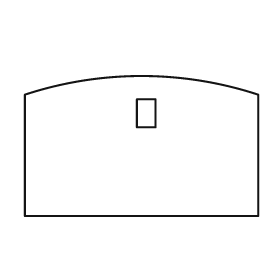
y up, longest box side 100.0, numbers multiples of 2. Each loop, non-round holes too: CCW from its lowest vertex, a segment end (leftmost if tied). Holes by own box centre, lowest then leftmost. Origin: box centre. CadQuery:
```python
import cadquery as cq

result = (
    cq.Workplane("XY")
    .moveTo(-50.0, -30.0)
    .lineTo(50.0, -30.0)
    .lineTo(50.0, 22.0)
    .threePointArc((0.0, 30.0), (-50.0, 22.0))
    .close()
    .moveTo(-2.0, 8.0)
    .lineTo(6.0, 8.0)
    .lineTo(6.0, 20.0)
    .lineTo(-2.0, 20.0)
    .close()
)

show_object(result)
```